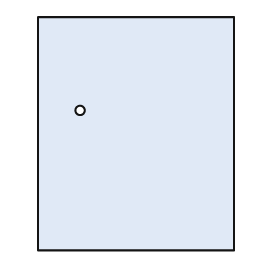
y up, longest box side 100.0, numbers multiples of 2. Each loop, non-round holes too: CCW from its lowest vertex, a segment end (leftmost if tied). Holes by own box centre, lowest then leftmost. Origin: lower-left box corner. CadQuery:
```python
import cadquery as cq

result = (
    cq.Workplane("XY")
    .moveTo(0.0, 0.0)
    .lineTo(84.0, 0.0)
    .lineTo(84.0, 100.0)
    .lineTo(0.0, 100.0)
    .close()
    .moveTo(18.0, 60.0)
    .circle(2.0)
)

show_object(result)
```